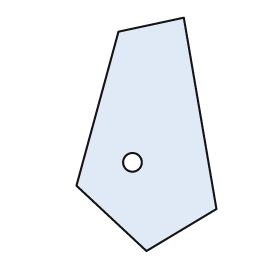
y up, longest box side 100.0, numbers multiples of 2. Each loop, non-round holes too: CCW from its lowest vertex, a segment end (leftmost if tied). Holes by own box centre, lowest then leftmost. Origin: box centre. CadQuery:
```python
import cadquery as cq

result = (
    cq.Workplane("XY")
    .moveTo(0.0, -50.0)
    .lineTo(30.0, -32.0)
    .lineTo(16.0, 50.0)
    .lineTo(-12.0, 44.0)
    .lineTo(-30.0, -22.0)
    .close()
    .moveTo(-6.0, -12.0)
    .circle(4.0)
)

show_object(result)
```